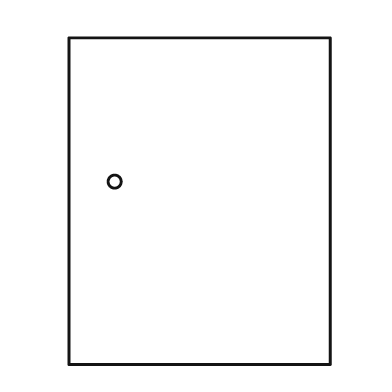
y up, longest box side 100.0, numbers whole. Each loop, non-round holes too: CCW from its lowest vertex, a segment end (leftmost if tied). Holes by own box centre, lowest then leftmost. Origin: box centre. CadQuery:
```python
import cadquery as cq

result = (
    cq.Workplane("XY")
    .moveTo(-40.0, -50.0)
    .lineTo(40.0, -50.0)
    .lineTo(40.0, 50.0)
    .lineTo(-40.0, 50.0)
    .close()
    .moveTo(-26.0, 6.0)
    .circle(2.0)
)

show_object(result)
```